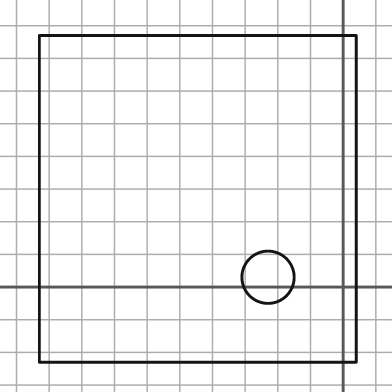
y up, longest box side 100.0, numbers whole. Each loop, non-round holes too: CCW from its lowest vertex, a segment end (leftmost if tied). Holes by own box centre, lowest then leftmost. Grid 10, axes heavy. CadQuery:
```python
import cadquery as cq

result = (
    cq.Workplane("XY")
    .moveTo(-93.0, -23.0)
    .lineTo(4.0, -23.0)
    .lineTo(4.0, 77.0)
    .lineTo(-93.0, 77.0)
    .close()
    .moveTo(-23.0, 3.0)
    .circle(8.0)
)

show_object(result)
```